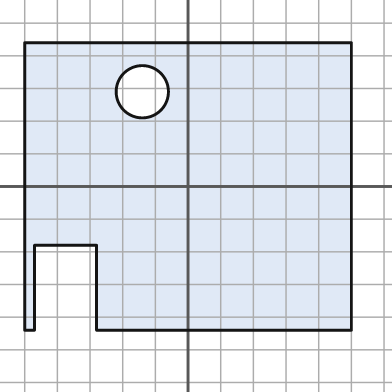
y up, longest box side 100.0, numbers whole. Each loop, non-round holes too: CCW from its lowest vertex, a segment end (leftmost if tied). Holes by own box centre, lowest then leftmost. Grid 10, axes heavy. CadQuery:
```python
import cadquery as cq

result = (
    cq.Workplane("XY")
    .moveTo(-50.0, -44.0)
    .lineTo(-47.0, -44.0)
    .lineTo(-47.0, -18.0)
    .lineTo(-28.0, -18.0)
    .lineTo(-28.0, -44.0)
    .lineTo(50.0, -44.0)
    .lineTo(50.0, 44.0)
    .lineTo(-50.0, 44.0)
    .close()
    .moveTo(-14.0, 29.0)
    .circle(8.0)
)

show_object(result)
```